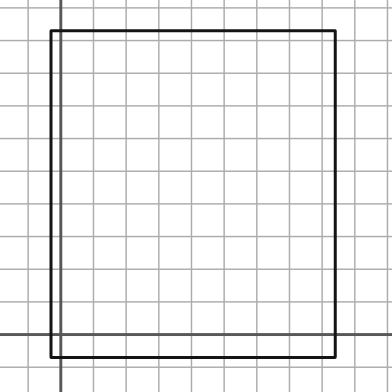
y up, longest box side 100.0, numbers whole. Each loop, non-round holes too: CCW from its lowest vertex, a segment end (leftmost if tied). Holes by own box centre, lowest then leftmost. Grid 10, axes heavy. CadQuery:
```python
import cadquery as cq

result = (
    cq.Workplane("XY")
    .moveTo(-3.0, -7.0)
    .lineTo(84.0, -7.0)
    .lineTo(84.0, 93.0)
    .lineTo(-3.0, 93.0)
    .close()
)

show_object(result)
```